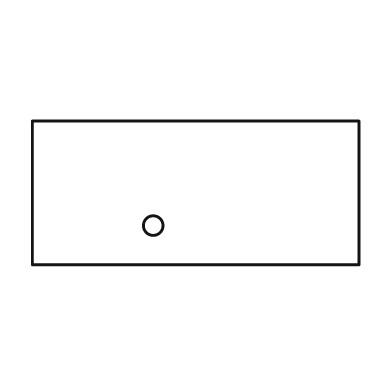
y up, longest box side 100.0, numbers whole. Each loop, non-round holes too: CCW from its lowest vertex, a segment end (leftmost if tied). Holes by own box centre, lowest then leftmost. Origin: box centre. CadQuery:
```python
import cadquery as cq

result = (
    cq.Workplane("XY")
    .moveTo(-50.0, -22.0)
    .lineTo(50.0, -22.0)
    .lineTo(50.0, 22.0)
    .lineTo(-50.0, 22.0)
    .close()
    .moveTo(-13.0, -10.0)
    .circle(3.0)
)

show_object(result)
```